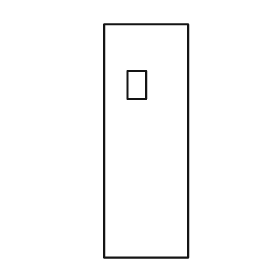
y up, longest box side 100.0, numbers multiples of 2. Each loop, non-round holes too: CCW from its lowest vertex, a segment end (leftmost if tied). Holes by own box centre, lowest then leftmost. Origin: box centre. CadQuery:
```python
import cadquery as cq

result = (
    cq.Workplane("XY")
    .moveTo(-18.0, -50.0)
    .lineTo(18.0, -50.0)
    .lineTo(18.0, 50.0)
    .lineTo(-18.0, 50.0)
    .close()
    .moveTo(-8.0, 18.0)
    .lineTo(0.0, 18.0)
    .lineTo(0.0, 30.0)
    .lineTo(-8.0, 30.0)
    .close()
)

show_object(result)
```